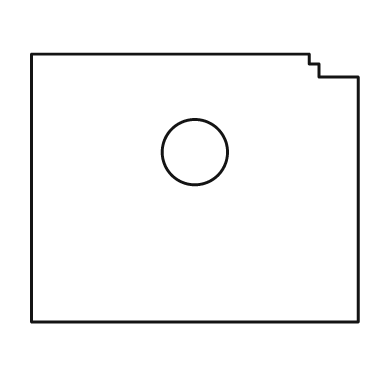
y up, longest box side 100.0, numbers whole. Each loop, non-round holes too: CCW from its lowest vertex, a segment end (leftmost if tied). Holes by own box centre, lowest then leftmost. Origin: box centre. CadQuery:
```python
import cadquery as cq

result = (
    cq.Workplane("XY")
    .moveTo(-50.0, -41.0)
    .lineTo(50.0, -41.0)
    .lineTo(50.0, 34.0)
    .lineTo(38.0, 34.0)
    .lineTo(38.0, 38.0)
    .lineTo(35.0, 38.0)
    .lineTo(35.0, 41.0)
    .lineTo(-50.0, 41.0)
    .close()
    .moveTo(0.0, 11.0)
    .circle(10.0)
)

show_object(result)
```